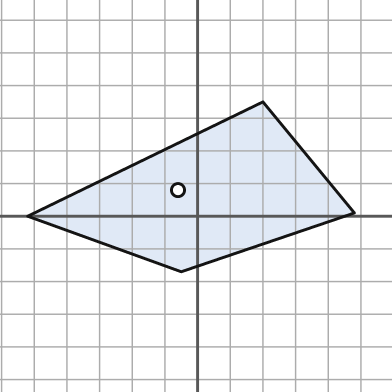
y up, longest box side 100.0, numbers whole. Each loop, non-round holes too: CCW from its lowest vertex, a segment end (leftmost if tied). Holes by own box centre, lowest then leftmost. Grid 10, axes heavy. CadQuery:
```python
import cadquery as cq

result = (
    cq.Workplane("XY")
    .moveTo(-5.0, -17.0)
    .lineTo(48.0, 1.0)
    .lineTo(20.0, 35.0)
    .lineTo(-52.0, 0.0)
    .close()
    .moveTo(-6.0, 8.0)
    .circle(2.0)
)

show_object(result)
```